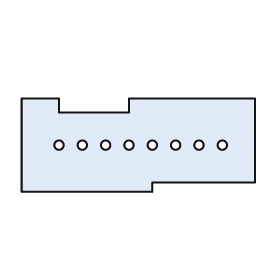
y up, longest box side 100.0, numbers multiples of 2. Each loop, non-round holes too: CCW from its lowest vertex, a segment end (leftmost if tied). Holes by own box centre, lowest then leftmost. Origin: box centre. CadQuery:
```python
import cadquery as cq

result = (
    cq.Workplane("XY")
    .moveTo(-50.0, -20.0)
    .lineTo(6.0, -20.0)
    .lineTo(6.0, -16.0)
    .lineTo(50.0, -16.0)
    .lineTo(50.0, 20.0)
    .lineTo(-4.0, 20.0)
    .lineTo(-4.0, 14.0)
    .lineTo(-34.0, 14.0)
    .lineTo(-34.0, 20.0)
    .lineTo(-50.0, 20.0)
    .close()
    .moveTo(-34.0, 0.0)
    .circle(2.0)
    .moveTo(-24.0, 0.0)
    .circle(2.0)
    .moveTo(-14.0, 0.0)
    .circle(2.0)
    .moveTo(-4.0, 0.0)
    .circle(2.0)
    .moveTo(6.0, 0.0)
    .circle(2.0)
    .moveTo(16.0, 0.0)
    .circle(2.0)
    .moveTo(26.0, 0.0)
    .circle(2.0)
    .moveTo(36.0, 0.0)
    .circle(2.0)
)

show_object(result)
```